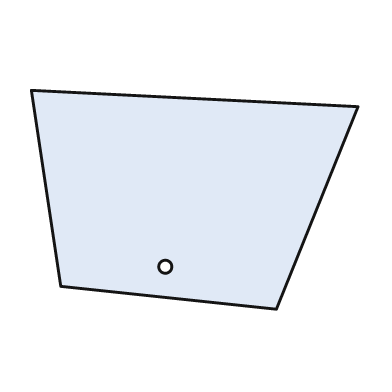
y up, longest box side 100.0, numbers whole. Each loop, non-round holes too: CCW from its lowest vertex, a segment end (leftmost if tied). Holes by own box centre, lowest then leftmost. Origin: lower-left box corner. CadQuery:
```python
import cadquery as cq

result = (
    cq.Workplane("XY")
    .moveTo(75.0, 0.0)
    .lineTo(100.0, 62.0)
    .lineTo(0.0, 67.0)
    .lineTo(9.0, 7.0)
    .close()
    .moveTo(41.0, 13.0)
    .circle(2.0)
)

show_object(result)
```